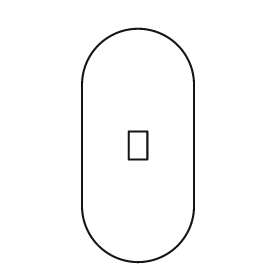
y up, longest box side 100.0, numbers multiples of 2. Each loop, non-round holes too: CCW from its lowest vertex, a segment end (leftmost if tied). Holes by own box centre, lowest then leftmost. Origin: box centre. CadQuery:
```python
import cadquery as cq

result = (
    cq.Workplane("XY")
    .moveTo(-24.0, -26.0)
    .threePointArc((0.0, -50.0), (24.0, -26.0))
    .lineTo(24.0, 26.0)
    .threePointArc((0.0, 50.0), (-24.0, 26.0))
    .close()
    .moveTo(-4.0, -6.0)
    .lineTo(4.0, -6.0)
    .lineTo(4.0, 6.0)
    .lineTo(-4.0, 6.0)
    .close()
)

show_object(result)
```